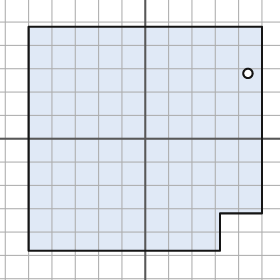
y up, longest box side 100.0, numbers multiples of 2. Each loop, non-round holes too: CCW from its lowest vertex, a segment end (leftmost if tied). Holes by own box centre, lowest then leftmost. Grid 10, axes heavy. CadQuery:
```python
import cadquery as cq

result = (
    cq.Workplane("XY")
    .moveTo(-50.0, -48.0)
    .lineTo(32.0, -48.0)
    .lineTo(32.0, -32.0)
    .lineTo(50.0, -32.0)
    .lineTo(50.0, 48.0)
    .lineTo(-50.0, 48.0)
    .close()
    .moveTo(44.0, 28.0)
    .circle(2.0)
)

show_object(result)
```